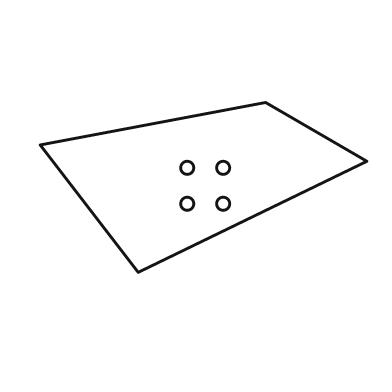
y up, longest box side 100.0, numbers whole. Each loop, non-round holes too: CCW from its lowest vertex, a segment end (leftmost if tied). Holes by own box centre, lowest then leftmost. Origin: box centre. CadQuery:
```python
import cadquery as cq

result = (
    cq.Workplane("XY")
    .moveTo(-20.0, -26.0)
    .lineTo(50.0, 8.0)
    .lineTo(19.0, 26.0)
    .lineTo(-50.0, 13.0)
    .close()
    .moveTo(-5.0, -5.0)
    .circle(2.0)
    .moveTo(6.0, -5.0)
    .circle(2.0)
    .moveTo(-5.0, 6.0)
    .circle(2.0)
    .moveTo(6.0, 6.0)
    .circle(2.0)
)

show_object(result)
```